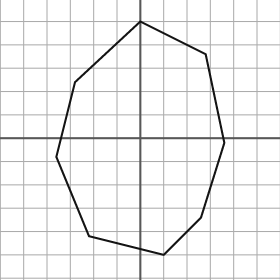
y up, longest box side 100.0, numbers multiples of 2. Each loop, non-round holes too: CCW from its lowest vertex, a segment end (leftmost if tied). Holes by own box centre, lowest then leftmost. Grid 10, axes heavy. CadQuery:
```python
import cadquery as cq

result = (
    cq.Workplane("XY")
    .moveTo(10.0, -50.0)
    .lineTo(26.0, -34.0)
    .lineTo(36.0, -2.0)
    .lineTo(28.0, 36.0)
    .lineTo(0.0, 50.0)
    .lineTo(-28.0, 24.0)
    .lineTo(-36.0, -8.0)
    .lineTo(-22.0, -42.0)
    .close()
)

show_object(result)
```